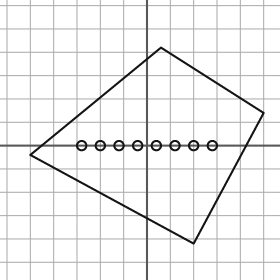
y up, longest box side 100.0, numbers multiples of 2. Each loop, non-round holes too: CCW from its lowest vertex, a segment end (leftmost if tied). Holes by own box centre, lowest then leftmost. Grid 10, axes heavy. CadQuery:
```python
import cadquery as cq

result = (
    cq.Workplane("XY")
    .moveTo(20.0, -42.0)
    .lineTo(50.0, 14.0)
    .lineTo(6.0, 42.0)
    .lineTo(-50.0, -4.0)
    .close()
    .moveTo(-28.0, 0.0)
    .circle(2.0)
    .moveTo(-20.0, 0.0)
    .circle(2.0)
    .moveTo(-12.0, 0.0)
    .circle(2.0)
    .moveTo(-4.0, 0.0)
    .circle(2.0)
    .moveTo(4.0, 0.0)
    .circle(2.0)
    .moveTo(12.0, 0.0)
    .circle(2.0)
    .moveTo(20.0, 0.0)
    .circle(2.0)
    .moveTo(28.0, 0.0)
    .circle(2.0)
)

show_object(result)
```